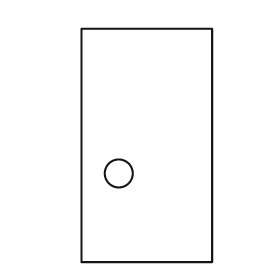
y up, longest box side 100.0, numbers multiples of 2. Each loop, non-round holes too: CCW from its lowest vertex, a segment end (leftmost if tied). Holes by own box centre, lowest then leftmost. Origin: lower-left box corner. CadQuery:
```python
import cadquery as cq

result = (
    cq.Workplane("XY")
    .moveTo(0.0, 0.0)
    .lineTo(56.0, 0.0)
    .lineTo(56.0, 100.0)
    .lineTo(0.0, 100.0)
    .close()
    .moveTo(16.0, 38.0)
    .circle(6.0)
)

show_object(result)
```